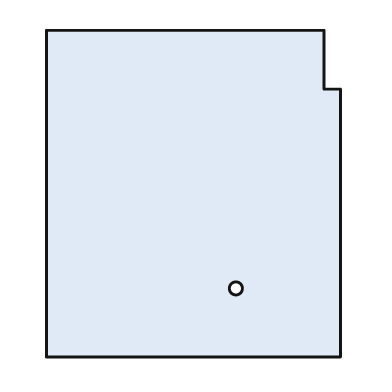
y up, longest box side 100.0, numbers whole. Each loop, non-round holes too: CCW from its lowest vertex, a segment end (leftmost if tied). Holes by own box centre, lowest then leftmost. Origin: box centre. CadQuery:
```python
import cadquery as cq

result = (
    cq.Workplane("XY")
    .moveTo(-45.0, -50.0)
    .lineTo(45.0, -50.0)
    .lineTo(45.0, 32.0)
    .lineTo(40.0, 32.0)
    .lineTo(40.0, 50.0)
    .lineTo(-45.0, 50.0)
    .close()
    .moveTo(13.0, -29.0)
    .circle(2.0)
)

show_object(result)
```